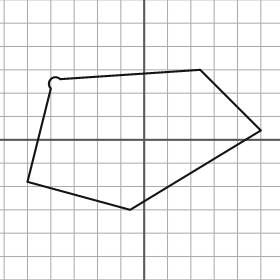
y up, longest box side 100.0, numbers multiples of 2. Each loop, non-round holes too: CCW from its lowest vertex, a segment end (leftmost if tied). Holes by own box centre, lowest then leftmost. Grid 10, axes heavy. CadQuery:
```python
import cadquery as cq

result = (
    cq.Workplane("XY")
    .moveTo(-6.0, -30.0)
    .lineTo(50.0, 4.0)
    .lineTo(24.0, 30.0)
    .lineTo(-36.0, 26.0)
    .threePointArc((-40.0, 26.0), (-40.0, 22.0))
    .lineTo(-50.0, -18.0)
    .close()
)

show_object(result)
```